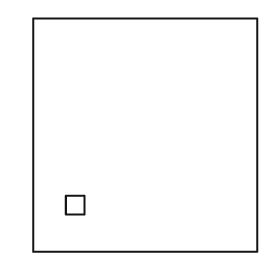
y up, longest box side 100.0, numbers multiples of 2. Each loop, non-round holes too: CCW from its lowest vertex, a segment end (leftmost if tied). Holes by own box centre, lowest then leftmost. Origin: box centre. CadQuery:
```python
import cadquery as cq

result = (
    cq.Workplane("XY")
    .moveTo(-48.0, -50.0)
    .lineTo(48.0, -50.0)
    .lineTo(48.0, 50.0)
    .lineTo(-48.0, 50.0)
    .close()
    .moveTo(-34.0, -34.0)
    .lineTo(-26.0, -34.0)
    .lineTo(-26.0, -26.0)
    .lineTo(-34.0, -26.0)
    .close()
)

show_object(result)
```